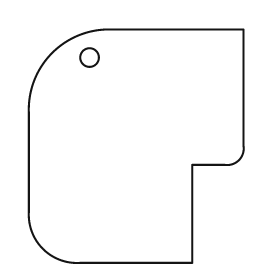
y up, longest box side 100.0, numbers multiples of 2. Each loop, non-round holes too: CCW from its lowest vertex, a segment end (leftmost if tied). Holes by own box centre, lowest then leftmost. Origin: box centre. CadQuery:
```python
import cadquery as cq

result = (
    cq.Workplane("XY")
    .moveTo(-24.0, -50.0)
    .lineTo(24.0, -50.0)
    .lineTo(24.0, -8.0)
    .lineTo(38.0, -8.0)
    .threePointArc((44.0, -6.0), (46.0, 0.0))
    .lineTo(46.0, 50.0)
    .lineTo(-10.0, 50.0)
    .threePointArc((-36.0, 40.0), (-46.0, 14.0))
    .lineTo(-46.0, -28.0)
    .threePointArc((-40.0, -44.0), (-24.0, -50.0))
    .close()
    .moveTo(-20.0, 38.0)
    .circle(4.0)
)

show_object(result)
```